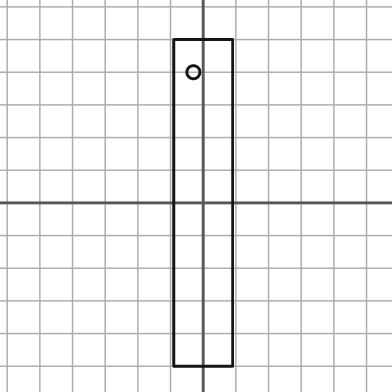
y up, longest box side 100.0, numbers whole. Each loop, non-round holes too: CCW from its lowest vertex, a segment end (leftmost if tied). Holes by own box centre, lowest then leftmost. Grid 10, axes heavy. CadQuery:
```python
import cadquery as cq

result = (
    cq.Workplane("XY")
    .moveTo(-9.0, -50.0)
    .lineTo(9.0, -50.0)
    .lineTo(9.0, 50.0)
    .lineTo(-9.0, 50.0)
    .close()
    .moveTo(-3.0, 40.0)
    .circle(2.0)
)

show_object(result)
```